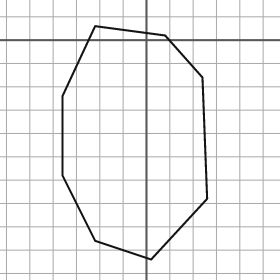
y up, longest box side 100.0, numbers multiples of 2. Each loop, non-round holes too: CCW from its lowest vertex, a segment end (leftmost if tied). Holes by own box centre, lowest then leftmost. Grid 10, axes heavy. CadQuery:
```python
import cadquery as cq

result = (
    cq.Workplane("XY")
    .moveTo(2.0, -94.0)
    .lineTo(26.0, -68.0)
    .lineTo(24.0, -16.0)
    .lineTo(8.0, 2.0)
    .lineTo(-22.0, 6.0)
    .lineTo(-36.0, -24.0)
    .lineTo(-36.0, -58.0)
    .lineTo(-22.0, -86.0)
    .close()
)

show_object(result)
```